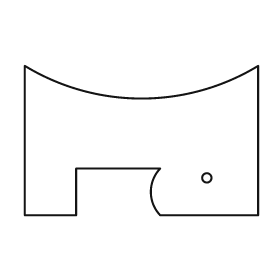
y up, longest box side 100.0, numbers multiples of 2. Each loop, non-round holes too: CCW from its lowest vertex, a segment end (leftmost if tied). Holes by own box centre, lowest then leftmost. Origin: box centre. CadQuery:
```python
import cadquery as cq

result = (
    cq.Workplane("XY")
    .moveTo(-50.0, -32.0)
    .lineTo(-28.0, -32.0)
    .lineTo(-28.0, -12.0)
    .lineTo(8.0, -12.0)
    .threePointArc((4.0, -22.0), (8.0, -32.0))
    .lineTo(50.0, -32.0)
    .lineTo(50.0, 32.0)
    .threePointArc((0.0, 18.0), (-50.0, 32.0))
    .close()
    .moveTo(28.0, -16.0)
    .circle(2.0)
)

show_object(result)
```